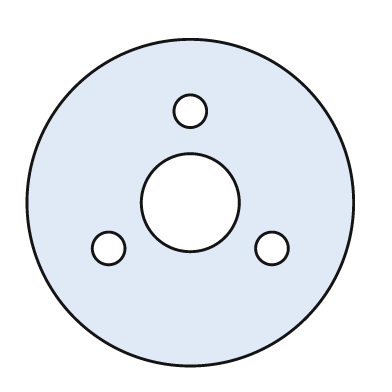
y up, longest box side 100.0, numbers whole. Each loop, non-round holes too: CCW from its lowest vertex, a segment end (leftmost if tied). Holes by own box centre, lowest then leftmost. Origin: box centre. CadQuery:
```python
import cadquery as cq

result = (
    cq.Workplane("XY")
    .moveTo(0.0, 0.0)
    .circle(50.0)
    .moveTo(-25.0, -14.0)
    .circle(5.0)
    .moveTo(25.0, -14.0)
    .circle(5.0)
    .moveTo(0.0, 0.0)
    .circle(15.0)
    .moveTo(0.0, 28.0)
    .circle(5.0)
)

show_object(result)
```